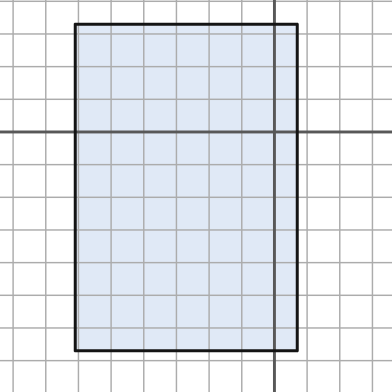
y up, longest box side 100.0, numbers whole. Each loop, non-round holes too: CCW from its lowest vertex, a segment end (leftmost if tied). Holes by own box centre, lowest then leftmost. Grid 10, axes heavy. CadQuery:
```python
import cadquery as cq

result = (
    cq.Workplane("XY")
    .moveTo(-61.0, -67.0)
    .lineTo(7.0, -67.0)
    .lineTo(7.0, 33.0)
    .lineTo(-61.0, 33.0)
    .close()
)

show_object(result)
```